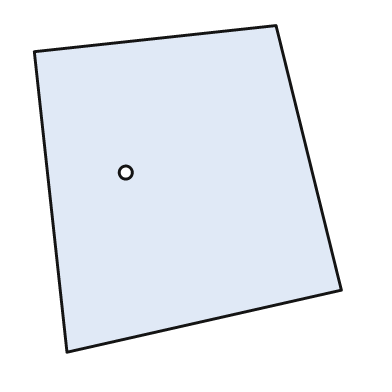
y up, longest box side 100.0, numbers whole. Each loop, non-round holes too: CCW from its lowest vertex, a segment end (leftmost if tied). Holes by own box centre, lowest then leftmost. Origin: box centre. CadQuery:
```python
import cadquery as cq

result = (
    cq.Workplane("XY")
    .moveTo(-37.0, -50.0)
    .lineTo(47.0, -31.0)
    .lineTo(27.0, 50.0)
    .lineTo(-47.0, 42.0)
    .close()
    .moveTo(-19.0, 5.0)
    .circle(2.0)
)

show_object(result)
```